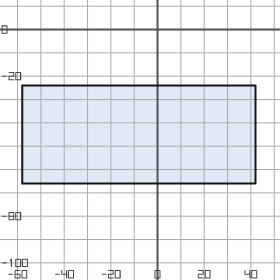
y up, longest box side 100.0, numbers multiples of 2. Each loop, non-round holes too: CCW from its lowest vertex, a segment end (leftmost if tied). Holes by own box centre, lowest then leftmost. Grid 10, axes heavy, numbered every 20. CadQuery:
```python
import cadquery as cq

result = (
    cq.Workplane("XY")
    .moveTo(-58.0, -66.0)
    .lineTo(42.0, -66.0)
    .lineTo(42.0, -24.0)
    .lineTo(-58.0, -24.0)
    .close()
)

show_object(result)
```